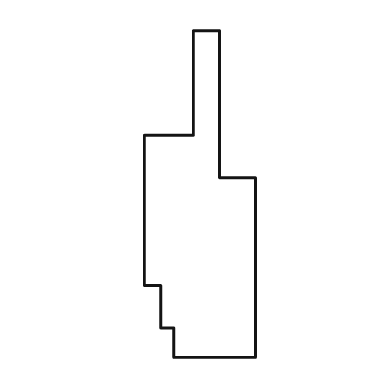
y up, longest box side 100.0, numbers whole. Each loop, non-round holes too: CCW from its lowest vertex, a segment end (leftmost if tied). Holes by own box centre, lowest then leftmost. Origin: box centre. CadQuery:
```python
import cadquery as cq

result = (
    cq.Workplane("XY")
    .moveTo(-8.0, -50.0)
    .lineTo(17.0, -50.0)
    .lineTo(17.0, 5.0)
    .lineTo(6.0, 5.0)
    .lineTo(6.0, 50.0)
    .lineTo(-2.0, 50.0)
    .lineTo(-2.0, 18.0)
    .lineTo(-17.0, 18.0)
    .lineTo(-17.0, -28.0)
    .lineTo(-12.0, -28.0)
    .lineTo(-12.0, -41.0)
    .lineTo(-8.0, -41.0)
    .close()
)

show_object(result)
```